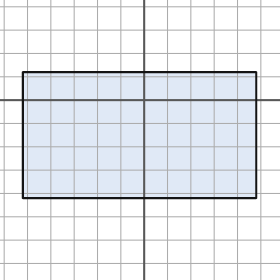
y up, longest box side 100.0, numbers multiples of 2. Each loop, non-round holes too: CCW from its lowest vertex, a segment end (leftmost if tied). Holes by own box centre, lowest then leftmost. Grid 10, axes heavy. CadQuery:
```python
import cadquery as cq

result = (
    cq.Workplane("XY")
    .moveTo(-52.0, -42.0)
    .lineTo(48.0, -42.0)
    .lineTo(48.0, 12.0)
    .lineTo(-52.0, 12.0)
    .close()
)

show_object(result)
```